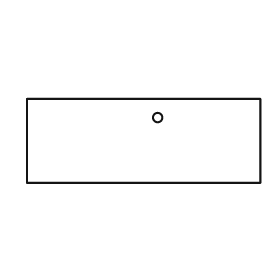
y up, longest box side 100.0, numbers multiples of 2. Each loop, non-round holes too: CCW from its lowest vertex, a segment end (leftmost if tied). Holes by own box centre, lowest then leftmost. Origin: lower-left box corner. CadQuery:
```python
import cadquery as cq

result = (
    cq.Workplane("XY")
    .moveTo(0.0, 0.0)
    .lineTo(100.0, 0.0)
    .lineTo(100.0, 36.0)
    .lineTo(0.0, 36.0)
    .close()
    .moveTo(56.0, 28.0)
    .circle(2.0)
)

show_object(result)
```